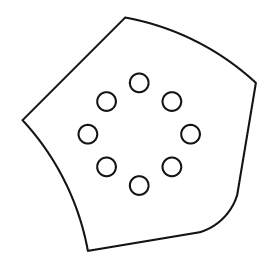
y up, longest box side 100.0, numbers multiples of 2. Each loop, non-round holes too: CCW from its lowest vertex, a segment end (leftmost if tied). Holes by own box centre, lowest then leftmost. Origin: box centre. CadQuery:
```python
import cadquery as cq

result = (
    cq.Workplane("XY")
    .moveTo(-22.0, -50.0)
    .lineTo(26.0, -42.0)
    .threePointArc((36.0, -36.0), (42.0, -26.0))
    .lineTo(50.0, 22.0)
    .threePointArc((24.0, 40.0), (-6.0, 50.0))
    .lineTo(-50.0, 6.0)
    .threePointArc((-32.0, -20.0), (-22.0, -50.0))
    .close()
    .moveTo(0.0, -22.0)
    .circle(4.0)
    .moveTo(-14.0, -14.0)
    .circle(4.0)
    .moveTo(14.0, -14.0)
    .circle(4.0)
    .moveTo(-22.0, 0.0)
    .circle(4.0)
    .moveTo(22.0, 0.0)
    .circle(4.0)
    .moveTo(-14.0, 14.0)
    .circle(4.0)
    .moveTo(14.0, 14.0)
    .circle(4.0)
    .moveTo(0.0, 22.0)
    .circle(4.0)
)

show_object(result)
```